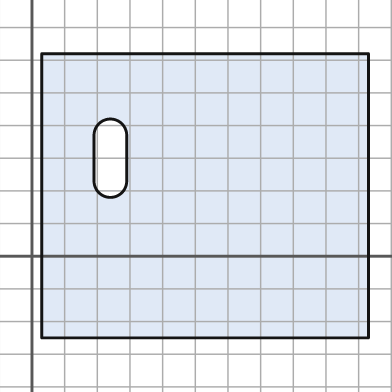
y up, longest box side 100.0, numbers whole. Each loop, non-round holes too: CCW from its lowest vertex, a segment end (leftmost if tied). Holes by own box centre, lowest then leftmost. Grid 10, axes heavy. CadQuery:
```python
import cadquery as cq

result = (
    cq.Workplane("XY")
    .moveTo(3.0, -25.0)
    .lineTo(103.0, -25.0)
    .lineTo(103.0, 62.0)
    .lineTo(3.0, 62.0)
    .close()
    .moveTo(19.0, 23.0)
    .threePointArc((24.0, 18.0), (29.0, 23.0))
    .lineTo(29.0, 37.0)
    .threePointArc((24.0, 42.0), (19.0, 37.0))
    .close()
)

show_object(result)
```